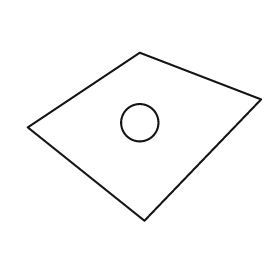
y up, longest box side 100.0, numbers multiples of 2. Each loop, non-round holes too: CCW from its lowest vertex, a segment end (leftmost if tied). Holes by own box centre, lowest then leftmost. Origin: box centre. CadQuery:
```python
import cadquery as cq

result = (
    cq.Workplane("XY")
    .moveTo(0.0, -36.0)
    .lineTo(50.0, 16.0)
    .lineTo(-2.0, 36.0)
    .lineTo(-50.0, 4.0)
    .close()
    .moveTo(-2.0, 6.0)
    .circle(8.0)
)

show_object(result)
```